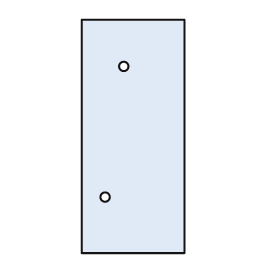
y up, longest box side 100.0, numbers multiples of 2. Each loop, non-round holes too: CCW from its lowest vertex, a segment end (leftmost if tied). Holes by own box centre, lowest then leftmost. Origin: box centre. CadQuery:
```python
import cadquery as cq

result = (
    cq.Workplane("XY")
    .moveTo(-22.0, -50.0)
    .lineTo(22.0, -50.0)
    .lineTo(22.0, 50.0)
    .lineTo(-22.0, 50.0)
    .close()
    .moveTo(-12.0, -26.0)
    .circle(2.0)
    .moveTo(-4.0, 30.0)
    .circle(2.0)
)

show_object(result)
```